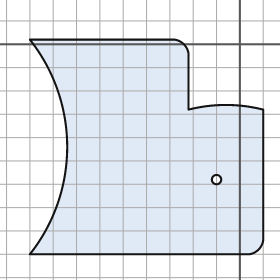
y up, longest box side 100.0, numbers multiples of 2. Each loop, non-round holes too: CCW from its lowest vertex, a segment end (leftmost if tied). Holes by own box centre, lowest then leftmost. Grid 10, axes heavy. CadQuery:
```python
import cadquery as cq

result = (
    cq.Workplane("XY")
    .moveTo(-90.0, -90.0)
    .lineTo(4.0, -90.0)
    .threePointArc((8.0, -88.0), (10.0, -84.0))
    .lineTo(10.0, -28.0)
    .threePointArc((-6.0, -26.0), (-22.0, -28.0))
    .lineTo(-22.0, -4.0)
    .threePointArc((-24.0, 0.0), (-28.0, 2.0))
    .lineTo(-90.0, 2.0)
    .threePointArc((-74.0, -44.0), (-90.0, -90.0))
    .close()
    .moveTo(-10.0, -58.0)
    .circle(2.0)
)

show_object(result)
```